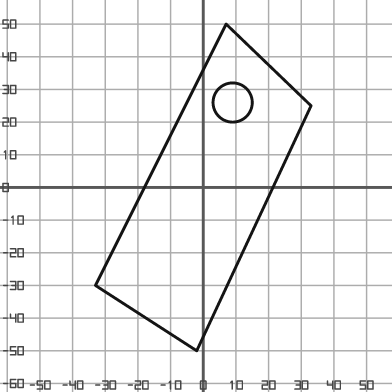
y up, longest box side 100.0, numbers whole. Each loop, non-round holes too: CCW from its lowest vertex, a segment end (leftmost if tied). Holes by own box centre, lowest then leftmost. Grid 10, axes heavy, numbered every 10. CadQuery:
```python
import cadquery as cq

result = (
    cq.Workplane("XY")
    .moveTo(-2.0, -50.0)
    .lineTo(33.0, 25.0)
    .lineTo(7.0, 50.0)
    .lineTo(-33.0, -30.0)
    .close()
    .moveTo(9.0, 26.0)
    .circle(6.0)
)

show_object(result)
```